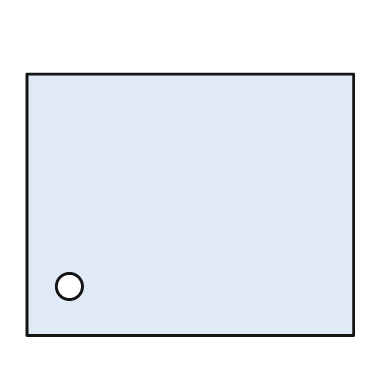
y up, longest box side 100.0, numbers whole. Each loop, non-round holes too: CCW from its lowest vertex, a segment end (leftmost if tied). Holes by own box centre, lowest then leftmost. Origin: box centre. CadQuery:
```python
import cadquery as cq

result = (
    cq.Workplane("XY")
    .moveTo(-50.0, -40.0)
    .lineTo(50.0, -40.0)
    .lineTo(50.0, 40.0)
    .lineTo(-50.0, 40.0)
    .close()
    .moveTo(-37.0, -25.0)
    .circle(4.0)
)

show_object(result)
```